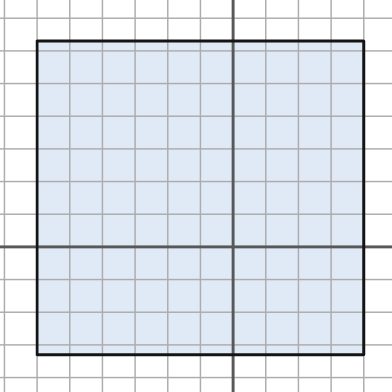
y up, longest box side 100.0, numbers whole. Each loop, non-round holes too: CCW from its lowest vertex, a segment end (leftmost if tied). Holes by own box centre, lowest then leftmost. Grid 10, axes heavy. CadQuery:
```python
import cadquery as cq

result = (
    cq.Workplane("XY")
    .moveTo(-60.0, -33.0)
    .lineTo(40.0, -33.0)
    .lineTo(40.0, 63.0)
    .lineTo(-60.0, 63.0)
    .close()
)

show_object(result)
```